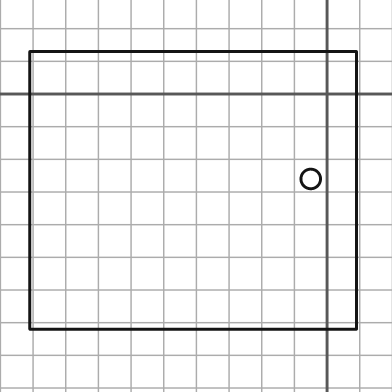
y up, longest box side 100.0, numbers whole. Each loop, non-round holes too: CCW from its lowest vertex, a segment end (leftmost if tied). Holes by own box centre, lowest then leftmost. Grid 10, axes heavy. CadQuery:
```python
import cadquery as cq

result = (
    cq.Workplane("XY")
    .moveTo(-91.0, -72.0)
    .lineTo(9.0, -72.0)
    .lineTo(9.0, 13.0)
    .lineTo(-91.0, 13.0)
    .close()
    .moveTo(-5.0, -26.0)
    .circle(3.0)
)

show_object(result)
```